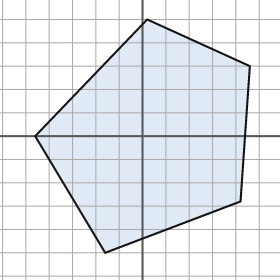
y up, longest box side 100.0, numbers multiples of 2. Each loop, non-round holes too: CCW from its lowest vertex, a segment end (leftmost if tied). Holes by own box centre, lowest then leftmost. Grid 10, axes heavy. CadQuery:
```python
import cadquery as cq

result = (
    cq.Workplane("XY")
    .moveTo(-16.0, -50.0)
    .lineTo(42.0, -28.0)
    .lineTo(46.0, 30.0)
    .lineTo(2.0, 50.0)
    .lineTo(-46.0, 0.0)
    .close()
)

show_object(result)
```